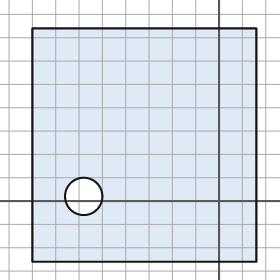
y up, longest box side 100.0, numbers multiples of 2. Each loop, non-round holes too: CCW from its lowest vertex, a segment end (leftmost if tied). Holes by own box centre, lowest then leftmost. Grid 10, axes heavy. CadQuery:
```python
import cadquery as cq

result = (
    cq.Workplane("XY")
    .moveTo(-80.0, -26.0)
    .lineTo(16.0, -26.0)
    .lineTo(16.0, 74.0)
    .lineTo(-80.0, 74.0)
    .close()
    .moveTo(-58.0, 2.0)
    .circle(8.0)
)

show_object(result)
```